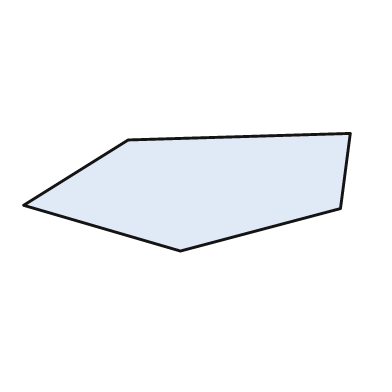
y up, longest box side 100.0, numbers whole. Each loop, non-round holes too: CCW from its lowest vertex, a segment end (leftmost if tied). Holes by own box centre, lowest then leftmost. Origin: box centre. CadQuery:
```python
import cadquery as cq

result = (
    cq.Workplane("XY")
    .moveTo(-2.0, -18.0)
    .lineTo(47.0, -5.0)
    .lineTo(50.0, 18.0)
    .lineTo(-18.0, 16.0)
    .lineTo(-50.0, -4.0)
    .close()
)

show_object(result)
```